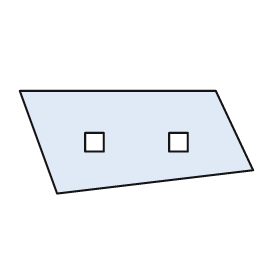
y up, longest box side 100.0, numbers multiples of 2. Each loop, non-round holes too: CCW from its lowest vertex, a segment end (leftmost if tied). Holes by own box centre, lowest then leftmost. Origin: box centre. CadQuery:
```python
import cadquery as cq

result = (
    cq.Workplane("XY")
    .moveTo(-34.0, -22.0)
    .lineTo(50.0, -12.0)
    .lineTo(34.0, 22.0)
    .lineTo(-50.0, 22.0)
    .close()
    .moveTo(-22.0, -4.0)
    .lineTo(-14.0, -4.0)
    .lineTo(-14.0, 4.0)
    .lineTo(-22.0, 4.0)
    .close()
    .moveTo(14.0, -4.0)
    .lineTo(22.0, -4.0)
    .lineTo(22.0, 4.0)
    .lineTo(14.0, 4.0)
    .close()
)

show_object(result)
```